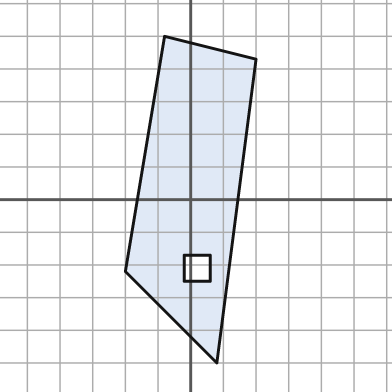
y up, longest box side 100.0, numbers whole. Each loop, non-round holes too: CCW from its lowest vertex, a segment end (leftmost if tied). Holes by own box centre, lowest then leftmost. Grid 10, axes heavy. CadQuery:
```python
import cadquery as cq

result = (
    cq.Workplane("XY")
    .moveTo(8.0, -50.0)
    .lineTo(20.0, 43.0)
    .lineTo(-8.0, 50.0)
    .lineTo(-20.0, -22.0)
    .close()
    .moveTo(-2.0, -25.0)
    .lineTo(6.0, -25.0)
    .lineTo(6.0, -17.0)
    .lineTo(-2.0, -17.0)
    .close()
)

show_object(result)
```